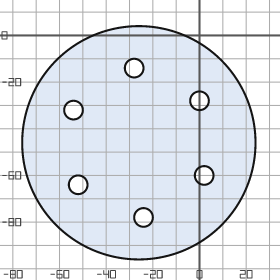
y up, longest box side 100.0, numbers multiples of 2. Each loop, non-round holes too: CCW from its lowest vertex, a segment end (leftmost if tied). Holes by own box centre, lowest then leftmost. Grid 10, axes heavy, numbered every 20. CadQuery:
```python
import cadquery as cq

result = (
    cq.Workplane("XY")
    .moveTo(-26.0, -46.0)
    .circle(50.0)
    .moveTo(-24.0, -78.0)
    .circle(4.0)
    .moveTo(-52.0, -64.0)
    .circle(4.0)
    .moveTo(2.0, -60.0)
    .circle(4.0)
    .moveTo(-54.0, -32.0)
    .circle(4.0)
    .moveTo(0.0, -28.0)
    .circle(4.0)
    .moveTo(-28.0, -14.0)
    .circle(4.0)
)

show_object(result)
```